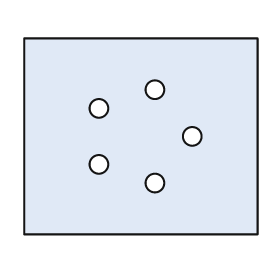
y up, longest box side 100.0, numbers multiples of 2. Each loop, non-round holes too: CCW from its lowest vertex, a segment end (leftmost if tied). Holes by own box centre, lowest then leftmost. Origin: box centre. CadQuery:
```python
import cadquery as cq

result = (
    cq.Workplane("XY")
    .moveTo(-50.0, -42.0)
    .lineTo(50.0, -42.0)
    .lineTo(50.0, 42.0)
    .lineTo(-50.0, 42.0)
    .close()
    .moveTo(6.0, -20.0)
    .circle(4.0)
    .moveTo(-18.0, -12.0)
    .circle(4.0)
    .moveTo(22.0, 0.0)
    .circle(4.0)
    .moveTo(-18.0, 12.0)
    .circle(4.0)
    .moveTo(6.0, 20.0)
    .circle(4.0)
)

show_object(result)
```